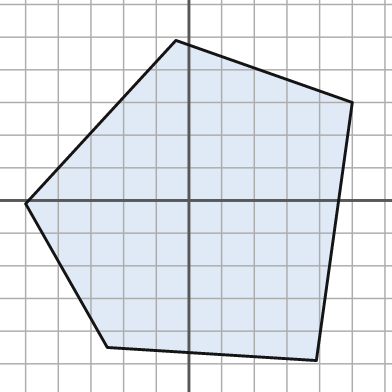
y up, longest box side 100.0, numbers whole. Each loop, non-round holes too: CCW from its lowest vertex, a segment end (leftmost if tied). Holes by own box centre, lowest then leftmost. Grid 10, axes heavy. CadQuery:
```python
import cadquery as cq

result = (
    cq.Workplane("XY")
    .moveTo(39.0, -49.0)
    .lineTo(50.0, 30.0)
    .lineTo(-4.0, 49.0)
    .lineTo(-50.0, -1.0)
    .lineTo(-25.0, -45.0)
    .close()
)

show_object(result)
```